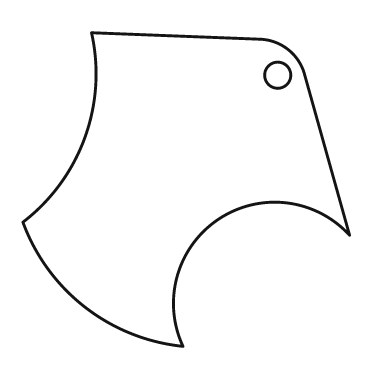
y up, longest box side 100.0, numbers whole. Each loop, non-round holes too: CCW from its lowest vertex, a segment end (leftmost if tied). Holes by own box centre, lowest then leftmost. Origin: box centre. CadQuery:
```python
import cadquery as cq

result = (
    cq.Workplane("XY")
    .moveTo(-1.0, -48.0)
    .threePointArc((10.0, -9.0), (50.0, -14.0))
    .lineTo(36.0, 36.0)
    .threePointArc((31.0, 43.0), (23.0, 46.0))
    .lineTo(-29.0, 48.0)
    .threePointArc((-31.0, 16.0), (-50.0, -10.0))
    .threePointArc((-31.0, -36.0), (-1.0, -48.0))
    .close()
    .moveTo(28.0, 35.0)
    .circle(4.0)
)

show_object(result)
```